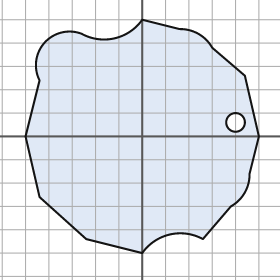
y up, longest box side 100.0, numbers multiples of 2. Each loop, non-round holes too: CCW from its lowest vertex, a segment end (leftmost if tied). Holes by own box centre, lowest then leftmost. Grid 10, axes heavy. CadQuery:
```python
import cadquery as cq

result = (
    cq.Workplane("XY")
    .moveTo(0.0, -50.0)
    .threePointArc((12.0, -42.0), (26.0, -44.0))
    .lineTo(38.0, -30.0)
    .threePointArc((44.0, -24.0), (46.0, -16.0))
    .lineTo(50.0, 0.0)
    .lineTo(44.0, 26.0)
    .lineTo(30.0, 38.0)
    .threePointArc((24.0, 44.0), (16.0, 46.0))
    .lineTo(0.0, 50.0)
    .threePointArc((-12.0, 42.0), (-26.0, 44.0))
    .threePointArc((-42.0, 40.0), (-44.0, 24.0))
    .lineTo(-50.0, 0.0)
    .lineTo(-44.0, -26.0)
    .lineTo(-24.0, -44.0)
    .close()
    .moveTo(40.0, 6.0)
    .circle(4.0)
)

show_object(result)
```